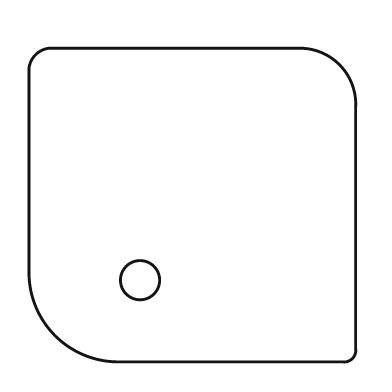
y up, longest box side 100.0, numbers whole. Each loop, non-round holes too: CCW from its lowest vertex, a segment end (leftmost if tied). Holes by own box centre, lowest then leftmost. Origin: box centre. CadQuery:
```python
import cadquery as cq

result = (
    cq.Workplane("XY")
    .moveTo(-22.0, -48.0)
    .lineTo(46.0, -48.0)
    .threePointArc((49.0, -47.0), (50.0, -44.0))
    .lineTo(50.0, 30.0)
    .threePointArc((45.0, 43.0), (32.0, 48.0))
    .lineTo(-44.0, 48.0)
    .threePointArc((-48.0, 46.0), (-50.0, 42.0))
    .lineTo(-50.0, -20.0)
    .threePointArc((-42.0, -40.0), (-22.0, -48.0))
    .close()
    .moveTo(-16.0, -23.0)
    .circle(6.0)
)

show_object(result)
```